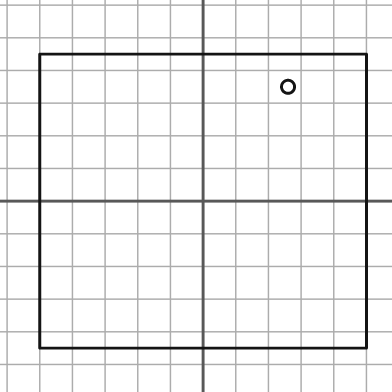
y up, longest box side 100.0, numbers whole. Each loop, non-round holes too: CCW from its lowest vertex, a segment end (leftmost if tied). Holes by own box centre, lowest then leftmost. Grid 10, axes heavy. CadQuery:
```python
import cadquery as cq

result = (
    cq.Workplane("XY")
    .moveTo(-50.0, -45.0)
    .lineTo(50.0, -45.0)
    .lineTo(50.0, 45.0)
    .lineTo(-50.0, 45.0)
    .close()
    .moveTo(26.0, 35.0)
    .circle(2.0)
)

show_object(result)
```